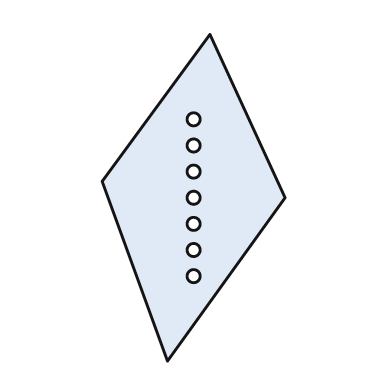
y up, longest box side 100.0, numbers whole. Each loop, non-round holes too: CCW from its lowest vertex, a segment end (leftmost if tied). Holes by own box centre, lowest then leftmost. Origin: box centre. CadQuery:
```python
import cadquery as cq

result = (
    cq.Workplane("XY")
    .moveTo(-8.0, -50.0)
    .lineTo(28.0, 0.0)
    .lineTo(5.0, 50.0)
    .lineTo(-28.0, 5.0)
    .close()
    .moveTo(0.0, -24.0)
    .circle(2.0)
    .moveTo(0.0, -16.0)
    .circle(2.0)
    .moveTo(0.0, -8.0)
    .circle(2.0)
    .moveTo(0.0, 0.0)
    .circle(2.0)
    .moveTo(0.0, 8.0)
    .circle(2.0)
    .moveTo(0.0, 16.0)
    .circle(2.0)
    .moveTo(0.0, 24.0)
    .circle(2.0)
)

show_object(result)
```